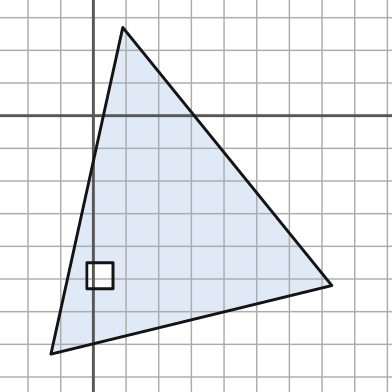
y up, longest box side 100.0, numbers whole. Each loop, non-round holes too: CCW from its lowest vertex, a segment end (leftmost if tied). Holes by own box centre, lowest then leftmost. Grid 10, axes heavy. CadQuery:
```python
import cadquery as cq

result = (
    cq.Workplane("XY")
    .moveTo(-13.0, -73.0)
    .lineTo(73.0, -52.0)
    .lineTo(9.0, 27.0)
    .close()
    .moveTo(-2.0, -53.0)
    .lineTo(6.0, -53.0)
    .lineTo(6.0, -45.0)
    .lineTo(-2.0, -45.0)
    .close()
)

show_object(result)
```